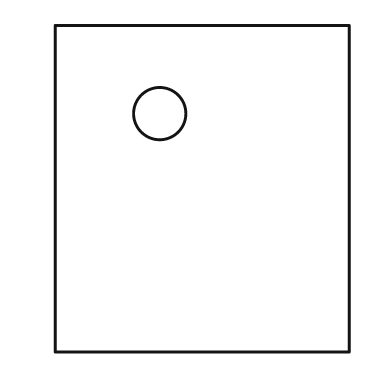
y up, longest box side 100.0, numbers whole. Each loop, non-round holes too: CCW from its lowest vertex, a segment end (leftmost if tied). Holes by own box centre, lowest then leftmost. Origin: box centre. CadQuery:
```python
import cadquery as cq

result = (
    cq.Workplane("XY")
    .moveTo(-45.0, -50.0)
    .lineTo(45.0, -50.0)
    .lineTo(45.0, 50.0)
    .lineTo(-45.0, 50.0)
    .close()
    .moveTo(-13.0, 23.0)
    .circle(8.0)
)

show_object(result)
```